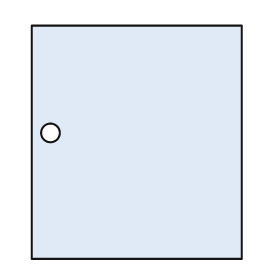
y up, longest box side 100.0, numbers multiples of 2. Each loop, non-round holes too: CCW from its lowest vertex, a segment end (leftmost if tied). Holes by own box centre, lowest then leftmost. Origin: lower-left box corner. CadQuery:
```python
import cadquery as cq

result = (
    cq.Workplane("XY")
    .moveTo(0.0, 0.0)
    .lineTo(90.0, 0.0)
    .lineTo(90.0, 100.0)
    .lineTo(0.0, 100.0)
    .close()
    .moveTo(8.0, 54.0)
    .circle(4.0)
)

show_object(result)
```